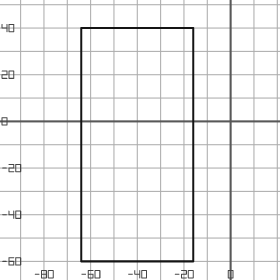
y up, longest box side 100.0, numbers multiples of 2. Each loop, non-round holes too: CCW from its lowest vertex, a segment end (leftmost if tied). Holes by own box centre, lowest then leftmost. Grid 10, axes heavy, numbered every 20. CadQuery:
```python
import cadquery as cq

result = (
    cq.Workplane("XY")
    .moveTo(-64.0, -60.0)
    .lineTo(-16.0, -60.0)
    .lineTo(-16.0, 40.0)
    .lineTo(-64.0, 40.0)
    .close()
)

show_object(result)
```